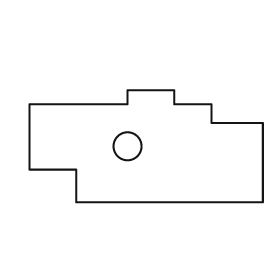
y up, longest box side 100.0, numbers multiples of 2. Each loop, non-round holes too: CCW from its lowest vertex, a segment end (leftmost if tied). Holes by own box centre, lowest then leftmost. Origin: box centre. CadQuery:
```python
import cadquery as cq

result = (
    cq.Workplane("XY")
    .moveTo(-30.0, -24.0)
    .lineTo(50.0, -24.0)
    .lineTo(50.0, 10.0)
    .lineTo(28.0, 10.0)
    .lineTo(28.0, 18.0)
    .lineTo(12.0, 18.0)
    .lineTo(12.0, 24.0)
    .lineTo(-8.0, 24.0)
    .lineTo(-8.0, 18.0)
    .lineTo(-50.0, 18.0)
    .lineTo(-50.0, -10.0)
    .lineTo(-30.0, -10.0)
    .close()
    .moveTo(-8.0, 0.0)
    .circle(6.0)
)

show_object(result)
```